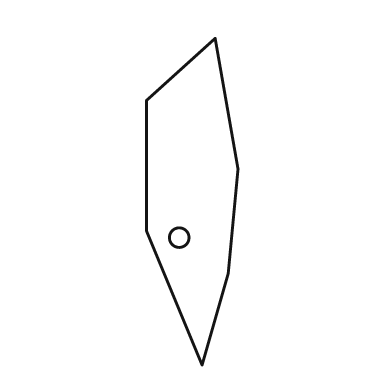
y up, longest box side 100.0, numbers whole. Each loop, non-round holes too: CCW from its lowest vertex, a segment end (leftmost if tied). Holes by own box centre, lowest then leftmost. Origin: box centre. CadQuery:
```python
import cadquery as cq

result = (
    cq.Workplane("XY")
    .moveTo(3.0, -50.0)
    .lineTo(11.0, -22.0)
    .lineTo(14.0, 10.0)
    .lineTo(7.0, 50.0)
    .lineTo(-14.0, 31.0)
    .lineTo(-14.0, -9.0)
    .close()
    .moveTo(-4.0, -11.0)
    .circle(3.0)
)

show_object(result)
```